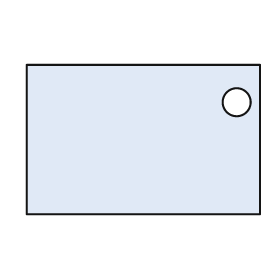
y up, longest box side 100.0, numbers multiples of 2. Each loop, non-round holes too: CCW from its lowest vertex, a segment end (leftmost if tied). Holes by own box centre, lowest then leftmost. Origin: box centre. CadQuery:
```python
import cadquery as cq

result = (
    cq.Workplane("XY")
    .moveTo(-50.0, -32.0)
    .lineTo(50.0, -32.0)
    .lineTo(50.0, 32.0)
    .lineTo(-50.0, 32.0)
    .close()
    .moveTo(40.0, 16.0)
    .circle(6.0)
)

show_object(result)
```